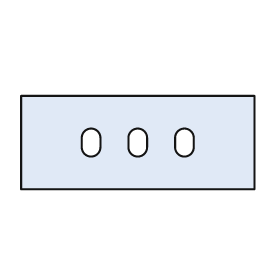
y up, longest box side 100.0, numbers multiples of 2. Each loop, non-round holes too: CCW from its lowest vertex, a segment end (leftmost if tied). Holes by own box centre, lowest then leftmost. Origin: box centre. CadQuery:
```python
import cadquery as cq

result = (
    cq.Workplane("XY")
    .moveTo(-50.0, -20.0)
    .lineTo(50.0, -20.0)
    .lineTo(50.0, 20.0)
    .lineTo(-50.0, 20.0)
    .close()
    .moveTo(-24.0, -2.0)
    .threePointArc((-20.0, -6.0), (-16.0, -2.0))
    .lineTo(-16.0, 2.0)
    .threePointArc((-20.0, 6.0), (-24.0, 2.0))
    .close()
    .moveTo(-4.0, -2.0)
    .threePointArc((0.0, -6.0), (4.0, -2.0))
    .lineTo(4.0, 2.0)
    .threePointArc((0.0, 6.0), (-4.0, 2.0))
    .close()
    .moveTo(16.0, -2.0)
    .threePointArc((20.0, -6.0), (24.0, -2.0))
    .lineTo(24.0, 2.0)
    .threePointArc((20.0, 6.0), (16.0, 2.0))
    .close()
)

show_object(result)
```